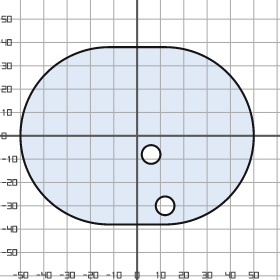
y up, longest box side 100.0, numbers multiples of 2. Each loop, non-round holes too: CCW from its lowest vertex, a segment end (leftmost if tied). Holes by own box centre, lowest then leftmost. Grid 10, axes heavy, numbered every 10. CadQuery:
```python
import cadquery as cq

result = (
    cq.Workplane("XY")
    .moveTo(-12.0, -38.0)
    .lineTo(12.0, -38.0)
    .threePointArc((50.0, 0.0), (12.0, 38.0))
    .lineTo(-12.0, 38.0)
    .threePointArc((-50.0, 0.0), (-12.0, -38.0))
    .close()
    .moveTo(12.0, -30.0)
    .circle(4.0)
    .moveTo(6.0, -8.0)
    .circle(4.0)
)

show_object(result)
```